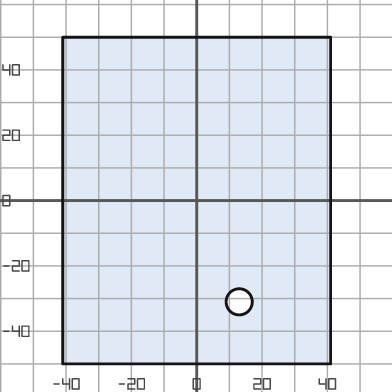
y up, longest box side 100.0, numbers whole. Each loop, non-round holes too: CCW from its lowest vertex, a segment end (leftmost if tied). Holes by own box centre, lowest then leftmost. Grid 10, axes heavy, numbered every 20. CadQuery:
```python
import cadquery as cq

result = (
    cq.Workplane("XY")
    .moveTo(-41.0, -50.0)
    .lineTo(41.0, -50.0)
    .lineTo(41.0, 50.0)
    .lineTo(-41.0, 50.0)
    .close()
    .moveTo(13.0, -31.0)
    .circle(4.0)
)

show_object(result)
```